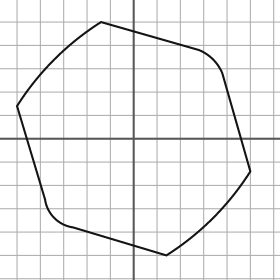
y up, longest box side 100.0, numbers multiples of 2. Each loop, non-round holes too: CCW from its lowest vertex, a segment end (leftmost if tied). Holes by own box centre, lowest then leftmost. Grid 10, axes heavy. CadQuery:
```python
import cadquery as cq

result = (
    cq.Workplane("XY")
    .moveTo(14.0, -50.0)
    .threePointArc((34.0, -34.0), (50.0, -14.0))
    .lineTo(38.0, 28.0)
    .threePointArc((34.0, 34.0), (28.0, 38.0))
    .lineTo(-14.0, 50.0)
    .threePointArc((-34.0, 34.0), (-50.0, 14.0))
    .lineTo(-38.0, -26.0)
    .threePointArc((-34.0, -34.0), (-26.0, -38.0))
    .close()
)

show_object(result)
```